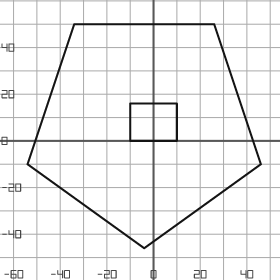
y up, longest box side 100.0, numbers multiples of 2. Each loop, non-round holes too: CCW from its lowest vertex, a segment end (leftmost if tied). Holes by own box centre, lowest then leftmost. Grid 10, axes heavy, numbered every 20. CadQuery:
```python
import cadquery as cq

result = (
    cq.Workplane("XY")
    .moveTo(-4.0, -46.0)
    .lineTo(46.0, -10.0)
    .lineTo(26.0, 50.0)
    .lineTo(-34.0, 50.0)
    .lineTo(-54.0, -10.0)
    .close()
    .moveTo(-10.0, 0.0)
    .lineTo(10.0, 0.0)
    .lineTo(10.0, 16.0)
    .lineTo(-10.0, 16.0)
    .close()
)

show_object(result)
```